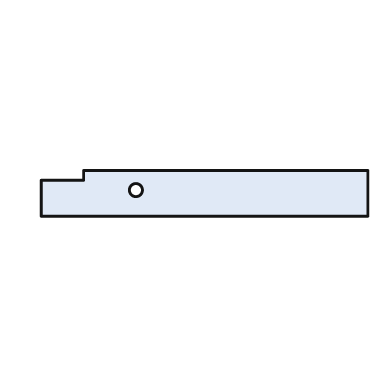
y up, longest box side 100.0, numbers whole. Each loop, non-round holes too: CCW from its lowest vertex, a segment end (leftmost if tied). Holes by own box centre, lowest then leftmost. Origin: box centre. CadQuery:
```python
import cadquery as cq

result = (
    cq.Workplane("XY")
    .moveTo(-50.0, -7.0)
    .lineTo(50.0, -7.0)
    .lineTo(50.0, 7.0)
    .lineTo(-37.0, 7.0)
    .lineTo(-37.0, 4.0)
    .lineTo(-50.0, 4.0)
    .close()
    .moveTo(-21.0, 1.0)
    .circle(2.0)
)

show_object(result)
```